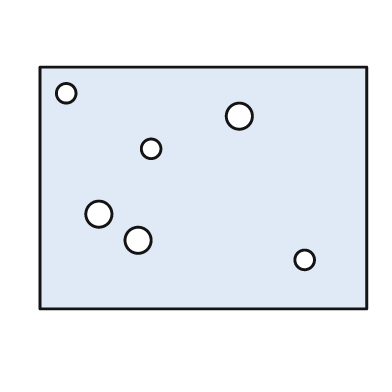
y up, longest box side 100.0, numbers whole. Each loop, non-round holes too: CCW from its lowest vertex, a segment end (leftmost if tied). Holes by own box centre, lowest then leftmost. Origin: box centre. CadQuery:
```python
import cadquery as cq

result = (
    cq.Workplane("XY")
    .moveTo(-50.0, -37.0)
    .lineTo(50.0, -37.0)
    .lineTo(50.0, 37.0)
    .lineTo(-50.0, 37.0)
    .close()
    .moveTo(31.0, -22.0)
    .circle(3.0)
    .moveTo(-20.0, -16.0)
    .circle(4.0)
    .moveTo(-32.0, -8.0)
    .circle(4.0)
    .moveTo(-16.0, 12.0)
    .circle(3.0)
    .moveTo(11.0, 22.0)
    .circle(4.0)
    .moveTo(-42.0, 29.0)
    .circle(3.0)
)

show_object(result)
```